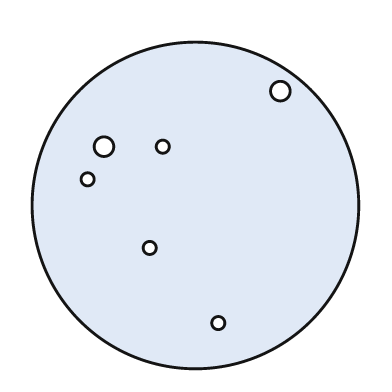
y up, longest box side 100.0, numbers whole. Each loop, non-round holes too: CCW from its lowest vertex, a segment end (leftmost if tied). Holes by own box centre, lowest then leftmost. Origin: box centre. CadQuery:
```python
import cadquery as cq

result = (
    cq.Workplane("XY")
    .moveTo(0.0, 0.0)
    .circle(50.0)
    .moveTo(7.0, -36.0)
    .circle(2.0)
    .moveTo(-14.0, -13.0)
    .circle(2.0)
    .moveTo(-33.0, 8.0)
    .circle(2.0)
    .moveTo(-28.0, 18.0)
    .circle(3.0)
    .moveTo(-10.0, 18.0)
    .circle(2.0)
    .moveTo(26.0, 35.0)
    .circle(3.0)
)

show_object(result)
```